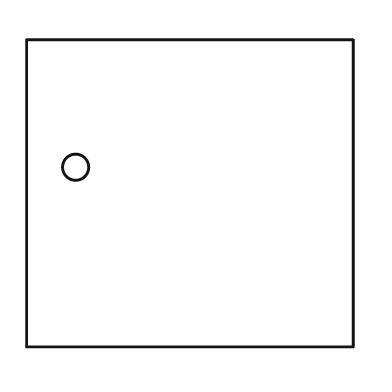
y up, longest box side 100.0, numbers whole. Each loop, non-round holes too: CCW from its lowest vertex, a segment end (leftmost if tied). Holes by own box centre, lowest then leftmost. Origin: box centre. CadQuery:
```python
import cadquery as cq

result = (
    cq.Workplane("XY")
    .moveTo(-50.0, -47.0)
    .lineTo(50.0, -47.0)
    .lineTo(50.0, 47.0)
    .lineTo(-50.0, 47.0)
    .close()
    .moveTo(-35.0, 8.0)
    .circle(4.0)
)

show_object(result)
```